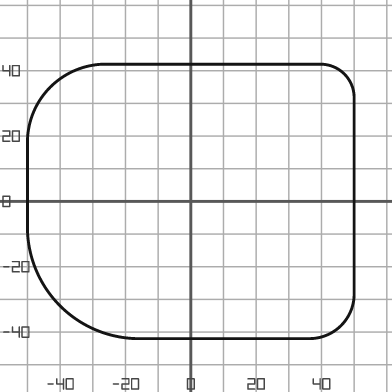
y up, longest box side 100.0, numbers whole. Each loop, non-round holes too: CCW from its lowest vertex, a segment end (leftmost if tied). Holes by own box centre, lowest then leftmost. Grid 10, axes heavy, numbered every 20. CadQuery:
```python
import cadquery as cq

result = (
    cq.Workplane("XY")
    .moveTo(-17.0, -42.0)
    .lineTo(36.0, -42.0)
    .threePointArc((46.0, -38.0), (50.0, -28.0))
    .lineTo(50.0, 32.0)
    .threePointArc((47.0, 39.0), (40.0, 42.0))
    .lineTo(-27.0, 42.0)
    .threePointArc((-43.0, 35.0), (-50.0, 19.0))
    .lineTo(-50.0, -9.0)
    .threePointArc((-40.0, -32.0), (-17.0, -42.0))
    .close()
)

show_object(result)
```